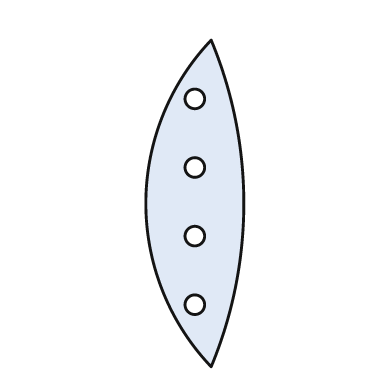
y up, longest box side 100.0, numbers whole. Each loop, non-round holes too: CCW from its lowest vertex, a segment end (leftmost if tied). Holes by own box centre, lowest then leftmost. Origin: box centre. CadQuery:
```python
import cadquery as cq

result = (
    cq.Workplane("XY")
    .moveTo(5.0, -50.0)
    .threePointArc((15.0, 0.0), (5.0, 50.0))
    .threePointArc((-15.0, 0.0), (5.0, -50.0))
    .close()
    .moveTo(0.0, -31.0)
    .circle(3.0)
    .moveTo(0.0, -10.0)
    .circle(3.0)
    .moveTo(0.0, 11.0)
    .circle(3.0)
    .moveTo(0.0, 32.0)
    .circle(3.0)
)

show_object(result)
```